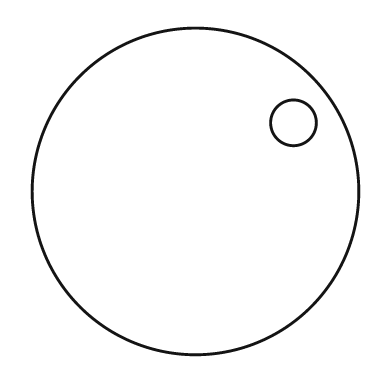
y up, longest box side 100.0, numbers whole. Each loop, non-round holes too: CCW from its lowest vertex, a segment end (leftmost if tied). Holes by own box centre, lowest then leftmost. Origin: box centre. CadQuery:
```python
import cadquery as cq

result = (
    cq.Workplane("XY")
    .moveTo(0.0, 0.0)
    .circle(50.0)
    .moveTo(30.0, 21.0)
    .circle(7.0)
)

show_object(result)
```